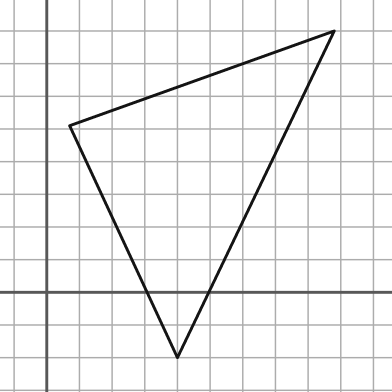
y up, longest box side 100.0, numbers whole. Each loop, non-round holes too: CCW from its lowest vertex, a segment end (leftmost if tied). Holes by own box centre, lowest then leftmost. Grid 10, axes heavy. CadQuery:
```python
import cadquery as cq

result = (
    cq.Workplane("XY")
    .moveTo(40.0, -20.0)
    .lineTo(88.0, 80.0)
    .lineTo(7.0, 51.0)
    .close()
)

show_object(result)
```